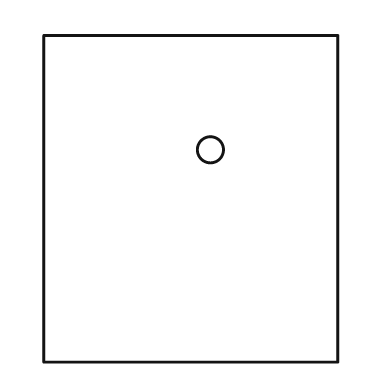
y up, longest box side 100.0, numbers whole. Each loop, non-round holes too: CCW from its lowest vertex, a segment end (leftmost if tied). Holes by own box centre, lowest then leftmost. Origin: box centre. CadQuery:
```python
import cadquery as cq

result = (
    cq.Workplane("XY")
    .moveTo(-45.0, -50.0)
    .lineTo(45.0, -50.0)
    .lineTo(45.0, 50.0)
    .lineTo(-45.0, 50.0)
    .close()
    .moveTo(6.0, 15.0)
    .circle(4.0)
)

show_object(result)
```